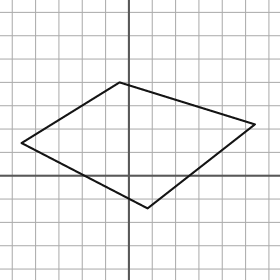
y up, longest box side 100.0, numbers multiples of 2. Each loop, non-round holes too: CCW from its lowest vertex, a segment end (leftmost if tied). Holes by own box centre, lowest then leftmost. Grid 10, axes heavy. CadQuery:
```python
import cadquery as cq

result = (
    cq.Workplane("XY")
    .moveTo(8.0, -14.0)
    .lineTo(54.0, 22.0)
    .lineTo(-4.0, 40.0)
    .lineTo(-46.0, 14.0)
    .close()
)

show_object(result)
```